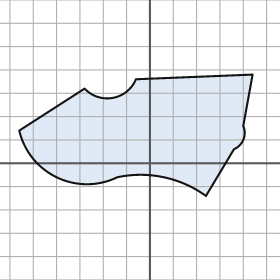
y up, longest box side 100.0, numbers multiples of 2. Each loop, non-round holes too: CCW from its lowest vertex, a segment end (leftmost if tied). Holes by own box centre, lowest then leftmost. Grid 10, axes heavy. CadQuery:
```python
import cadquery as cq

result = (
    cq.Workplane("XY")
    .moveTo(24.0, -14.0)
    .lineTo(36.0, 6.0)
    .threePointArc((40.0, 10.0), (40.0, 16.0))
    .lineTo(44.0, 38.0)
    .lineTo(-6.0, 36.0)
    .threePointArc((-16.0, 28.0), (-28.0, 32.0))
    .lineTo(-56.0, 14.0)
    .threePointArc((-40.0, -6.0), (-14.0, -6.0))
    .threePointArc((6.0, -6.0), (24.0, -14.0))
    .close()
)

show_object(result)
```